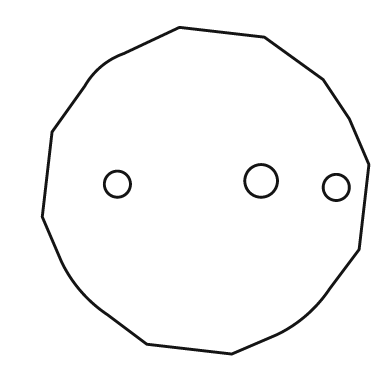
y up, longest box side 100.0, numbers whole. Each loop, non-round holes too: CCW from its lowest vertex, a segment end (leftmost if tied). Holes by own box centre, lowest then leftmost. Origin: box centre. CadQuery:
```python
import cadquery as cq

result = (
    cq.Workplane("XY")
    .moveTo(8.0, -50.0)
    .lineTo(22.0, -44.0)
    .threePointArc((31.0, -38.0), (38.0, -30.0))
    .lineTo(47.0, -18.0)
    .lineTo(50.0, 8.0)
    .lineTo(44.0, 22.0)
    .lineTo(36.0, 34.0)
    .lineTo(18.0, 47.0)
    .lineTo(-8.0, 50.0)
    .lineTo(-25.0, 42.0)
    .threePointArc((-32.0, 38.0), (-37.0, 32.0))
    .lineTo(-47.0, 18.0)
    .lineTo(-50.0, -8.0)
    .lineTo(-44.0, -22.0)
    .threePointArc((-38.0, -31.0), (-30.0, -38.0))
    .lineTo(-18.0, -47.0)
    .close()
    .moveTo(40.0, 1.0)
    .circle(4.0)
    .moveTo(-27.0, 2.0)
    .circle(4.0)
    .moveTo(17.0, 3.0)
    .circle(5.0)
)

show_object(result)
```